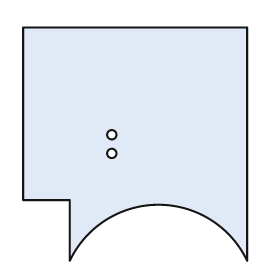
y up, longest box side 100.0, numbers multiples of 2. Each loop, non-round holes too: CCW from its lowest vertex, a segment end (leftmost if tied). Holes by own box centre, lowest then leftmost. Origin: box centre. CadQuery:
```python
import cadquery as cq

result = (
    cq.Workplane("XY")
    .moveTo(-28.0, -50.0)
    .threePointArc((10.0, -26.0), (48.0, -50.0))
    .lineTo(48.0, 50.0)
    .lineTo(-48.0, 50.0)
    .lineTo(-48.0, -24.0)
    .lineTo(-28.0, -24.0)
    .close()
    .moveTo(-10.0, -4.0)
    .circle(2.0)
    .moveTo(-10.0, 4.0)
    .circle(2.0)
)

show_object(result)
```